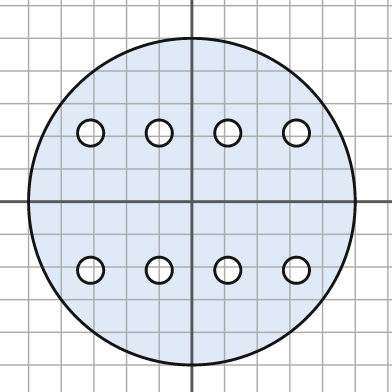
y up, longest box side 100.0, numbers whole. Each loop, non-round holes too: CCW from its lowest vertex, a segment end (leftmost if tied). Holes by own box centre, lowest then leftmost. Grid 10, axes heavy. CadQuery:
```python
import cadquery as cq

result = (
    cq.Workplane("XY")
    .moveTo(0.0, 0.0)
    .circle(50.0)
    .moveTo(-31.0, -21.0)
    .circle(4.0)
    .moveTo(-10.0, -21.0)
    .circle(4.0)
    .moveTo(11.0, -21.0)
    .circle(4.0)
    .moveTo(32.0, -21.0)
    .circle(4.0)
    .moveTo(-31.0, 21.0)
    .circle(4.0)
    .moveTo(-10.0, 21.0)
    .circle(4.0)
    .moveTo(11.0, 21.0)
    .circle(4.0)
    .moveTo(32.0, 21.0)
    .circle(4.0)
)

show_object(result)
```